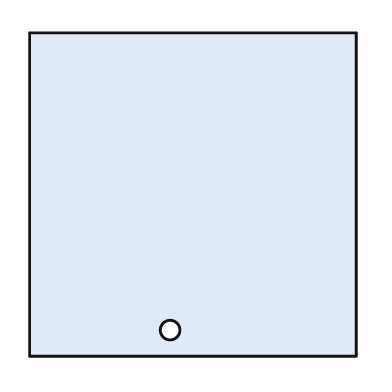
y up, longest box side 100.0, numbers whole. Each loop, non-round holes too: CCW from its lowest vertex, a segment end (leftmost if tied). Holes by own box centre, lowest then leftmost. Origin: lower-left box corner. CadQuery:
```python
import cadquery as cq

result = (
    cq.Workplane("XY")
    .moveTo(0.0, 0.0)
    .lineTo(100.0, 0.0)
    .lineTo(100.0, 99.0)
    .lineTo(0.0, 99.0)
    .close()
    .moveTo(43.0, 8.0)
    .circle(3.0)
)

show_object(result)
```